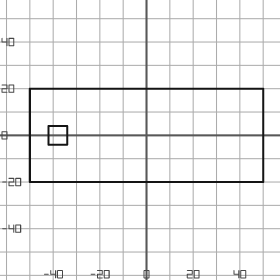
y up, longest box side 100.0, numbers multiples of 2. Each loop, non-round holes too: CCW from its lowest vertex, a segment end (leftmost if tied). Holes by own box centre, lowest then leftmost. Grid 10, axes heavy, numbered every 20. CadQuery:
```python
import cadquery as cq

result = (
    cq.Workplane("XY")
    .moveTo(-50.0, -20.0)
    .lineTo(50.0, -20.0)
    .lineTo(50.0, 20.0)
    .lineTo(-50.0, 20.0)
    .close()
    .moveTo(-42.0, -4.0)
    .lineTo(-34.0, -4.0)
    .lineTo(-34.0, 4.0)
    .lineTo(-42.0, 4.0)
    .close()
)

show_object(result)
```